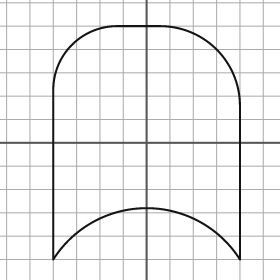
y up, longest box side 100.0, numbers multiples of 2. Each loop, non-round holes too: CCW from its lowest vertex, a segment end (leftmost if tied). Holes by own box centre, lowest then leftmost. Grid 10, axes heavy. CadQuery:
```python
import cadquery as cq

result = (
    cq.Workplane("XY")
    .moveTo(-40.0, -50.0)
    .threePointArc((0.0, -28.0), (40.0, -50.0))
    .lineTo(40.0, 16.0)
    .threePointArc((30.0, 40.0), (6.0, 50.0))
    .lineTo(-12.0, 50.0)
    .threePointArc((-32.0, 42.0), (-40.0, 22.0))
    .close()
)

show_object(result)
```